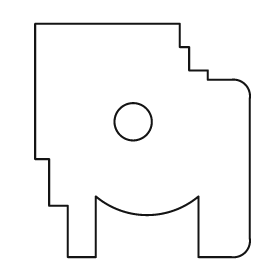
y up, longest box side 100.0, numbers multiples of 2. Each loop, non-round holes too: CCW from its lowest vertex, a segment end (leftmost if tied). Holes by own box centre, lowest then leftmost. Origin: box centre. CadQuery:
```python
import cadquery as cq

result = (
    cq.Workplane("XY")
    .moveTo(-32.0, -50.0)
    .lineTo(-20.0, -50.0)
    .lineTo(-20.0, -24.0)
    .threePointArc((2.0, -32.0), (24.0, -24.0))
    .lineTo(24.0, -50.0)
    .lineTo(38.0, -50.0)
    .threePointArc((44.0, -48.0), (46.0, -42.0))
    .lineTo(46.0, 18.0)
    .threePointArc((44.0, 24.0), (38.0, 26.0))
    .lineTo(28.0, 26.0)
    .lineTo(28.0, 30.0)
    .lineTo(20.0, 30.0)
    .lineTo(20.0, 40.0)
    .lineTo(16.0, 40.0)
    .lineTo(16.0, 50.0)
    .lineTo(-46.0, 50.0)
    .lineTo(-46.0, -8.0)
    .lineTo(-40.0, -8.0)
    .lineTo(-40.0, -28.0)
    .lineTo(-32.0, -28.0)
    .close()
    .moveTo(-4.0, 8.0)
    .circle(8.0)
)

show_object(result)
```